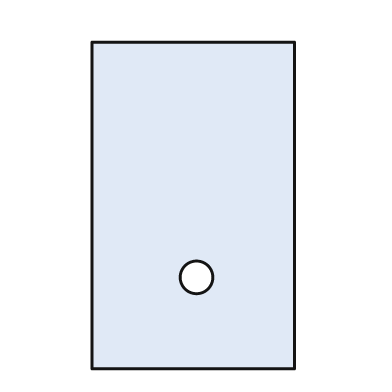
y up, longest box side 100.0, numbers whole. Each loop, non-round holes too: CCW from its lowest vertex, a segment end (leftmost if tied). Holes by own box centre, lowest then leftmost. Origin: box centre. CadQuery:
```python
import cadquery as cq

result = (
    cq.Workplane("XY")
    .moveTo(-31.0, -50.0)
    .lineTo(31.0, -50.0)
    .lineTo(31.0, 50.0)
    .lineTo(-31.0, 50.0)
    .close()
    .moveTo(1.0, -22.0)
    .circle(5.0)
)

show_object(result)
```